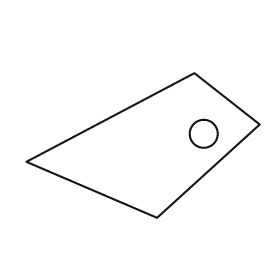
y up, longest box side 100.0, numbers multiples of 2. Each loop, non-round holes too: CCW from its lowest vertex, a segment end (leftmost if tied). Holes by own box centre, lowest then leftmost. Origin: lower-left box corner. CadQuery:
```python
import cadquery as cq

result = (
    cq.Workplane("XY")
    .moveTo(56.0, 0.0)
    .lineTo(100.0, 40.0)
    .lineTo(72.0, 62.0)
    .lineTo(0.0, 24.0)
    .close()
    .moveTo(76.0, 36.0)
    .circle(6.0)
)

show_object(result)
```